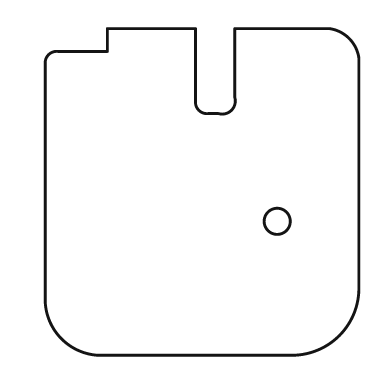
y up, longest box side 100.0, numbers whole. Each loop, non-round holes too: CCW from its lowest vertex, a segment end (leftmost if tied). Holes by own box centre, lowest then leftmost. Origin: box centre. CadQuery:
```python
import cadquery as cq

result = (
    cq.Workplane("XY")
    .moveTo(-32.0, -50.0)
    .lineTo(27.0, -50.0)
    .threePointArc((42.0, -44.0), (48.0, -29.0))
    .lineTo(48.0, 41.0)
    .threePointArc((45.0, 47.0), (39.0, 50.0))
    .lineTo(10.0, 50.0)
    .lineTo(10.0, 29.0)
    .threePointArc((9.0, 25.0), (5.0, 24.0))
    .lineTo(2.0, 24.0)
    .threePointArc((-1.0, 25.0), (-2.0, 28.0))
    .lineTo(-2.0, 50.0)
    .lineTo(-29.0, 50.0)
    .lineTo(-29.0, 43.0)
    .lineTo(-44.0, 43.0)
    .threePointArc((-47.0, 42.0), (-48.0, 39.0))
    .lineTo(-48.0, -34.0)
    .threePointArc((-43.0, -45.0), (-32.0, -50.0))
    .close()
    .moveTo(23.0, -9.0)
    .circle(4.0)
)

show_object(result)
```